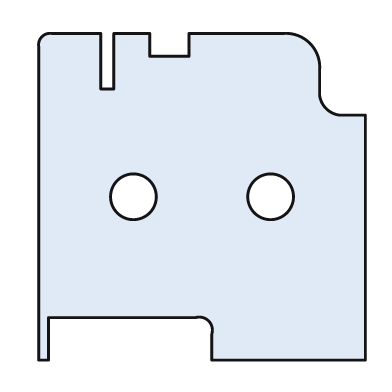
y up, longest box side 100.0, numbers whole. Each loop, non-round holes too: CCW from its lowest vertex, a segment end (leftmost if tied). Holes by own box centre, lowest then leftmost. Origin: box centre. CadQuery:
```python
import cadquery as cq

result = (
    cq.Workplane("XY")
    .moveTo(-50.0, -50.0)
    .lineTo(-47.0, -50.0)
    .lineTo(-47.0, -37.0)
    .lineTo(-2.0, -37.0)
    .threePointArc((2.0, -38.0), (3.0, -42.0))
    .lineTo(3.0, -50.0)
    .lineTo(50.0, -50.0)
    .lineTo(50.0, 25.0)
    .lineTo(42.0, 25.0)
    .threePointArc((38.0, 27.0), (36.0, 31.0))
    .lineTo(36.0, 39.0)
    .threePointArc((33.0, 47.0), (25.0, 50.0))
    .lineTo(-4.0, 50.0)
    .lineTo(-4.0, 43.0)
    .lineTo(-16.0, 43.0)
    .lineTo(-16.0, 50.0)
    .lineTo(-27.0, 50.0)
    .lineTo(-27.0, 33.0)
    .lineTo(-31.0, 33.0)
    .lineTo(-31.0, 50.0)
    .lineTo(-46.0, 50.0)
    .threePointArc((-49.0, 49.0), (-50.0, 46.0))
    .close()
    .moveTo(-21.0, 0.0)
    .circle(7.0)
    .moveTo(21.0, 0.0)
    .circle(7.0)
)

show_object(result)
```